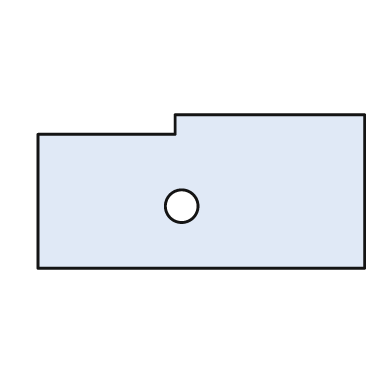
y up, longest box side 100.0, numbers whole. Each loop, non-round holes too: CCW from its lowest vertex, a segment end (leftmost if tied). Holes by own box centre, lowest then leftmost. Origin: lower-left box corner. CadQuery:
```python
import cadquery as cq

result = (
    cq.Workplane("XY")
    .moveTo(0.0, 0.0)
    .lineTo(100.0, 0.0)
    .lineTo(100.0, 47.0)
    .lineTo(42.0, 47.0)
    .lineTo(42.0, 41.0)
    .lineTo(0.0, 41.0)
    .close()
    .moveTo(44.0, 19.0)
    .circle(5.0)
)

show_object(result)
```